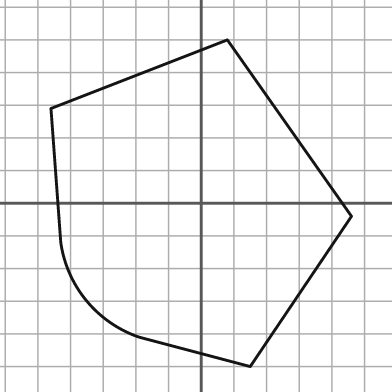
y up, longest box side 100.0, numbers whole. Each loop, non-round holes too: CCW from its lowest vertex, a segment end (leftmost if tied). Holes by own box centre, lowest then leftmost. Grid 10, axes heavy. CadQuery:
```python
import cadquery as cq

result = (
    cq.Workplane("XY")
    .moveTo(15.0, -50.0)
    .lineTo(46.0, -4.0)
    .lineTo(8.0, 50.0)
    .lineTo(-46.0, 29.0)
    .lineTo(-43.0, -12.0)
    .threePointArc((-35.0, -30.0), (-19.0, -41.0))
    .close()
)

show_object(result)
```